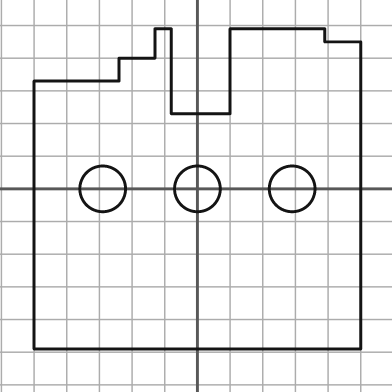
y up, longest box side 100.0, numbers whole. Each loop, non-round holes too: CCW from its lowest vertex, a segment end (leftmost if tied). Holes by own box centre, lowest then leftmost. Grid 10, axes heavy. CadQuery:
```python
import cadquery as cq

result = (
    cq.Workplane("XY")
    .moveTo(-50.0, -49.0)
    .lineTo(50.0, -49.0)
    .lineTo(50.0, 45.0)
    .lineTo(39.0, 45.0)
    .lineTo(39.0, 49.0)
    .lineTo(10.0, 49.0)
    .lineTo(10.0, 23.0)
    .lineTo(-8.0, 23.0)
    .lineTo(-8.0, 49.0)
    .lineTo(-13.0, 49.0)
    .lineTo(-13.0, 40.0)
    .lineTo(-24.0, 40.0)
    .lineTo(-24.0, 33.0)
    .lineTo(-50.0, 33.0)
    .close()
    .moveTo(-29.0, 0.0)
    .circle(7.0)
    .moveTo(0.0, 0.0)
    .circle(7.0)
    .moveTo(29.0, 0.0)
    .circle(7.0)
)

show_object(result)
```